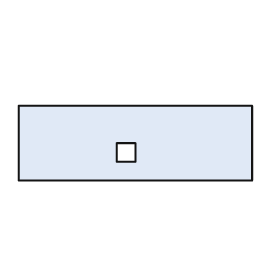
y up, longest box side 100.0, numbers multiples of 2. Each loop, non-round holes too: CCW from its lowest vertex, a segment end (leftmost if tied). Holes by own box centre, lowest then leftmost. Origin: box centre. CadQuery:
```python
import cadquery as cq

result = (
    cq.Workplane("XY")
    .moveTo(-50.0, -16.0)
    .lineTo(50.0, -16.0)
    .lineTo(50.0, 16.0)
    .lineTo(-50.0, 16.0)
    .close()
    .moveTo(-8.0, -8.0)
    .lineTo(0.0, -8.0)
    .lineTo(0.0, 0.0)
    .lineTo(-8.0, 0.0)
    .close()
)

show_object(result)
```